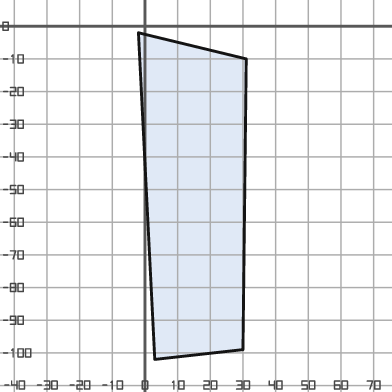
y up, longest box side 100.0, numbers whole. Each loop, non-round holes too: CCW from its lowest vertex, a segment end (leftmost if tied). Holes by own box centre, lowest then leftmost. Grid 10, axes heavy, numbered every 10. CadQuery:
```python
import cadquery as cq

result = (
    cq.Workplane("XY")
    .moveTo(3.0, -102.0)
    .lineTo(30.0, -99.0)
    .lineTo(31.0, -10.0)
    .lineTo(-2.0, -2.0)
    .close()
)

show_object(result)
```